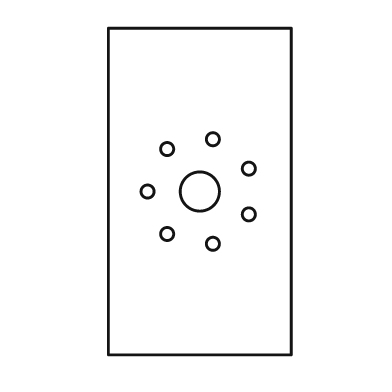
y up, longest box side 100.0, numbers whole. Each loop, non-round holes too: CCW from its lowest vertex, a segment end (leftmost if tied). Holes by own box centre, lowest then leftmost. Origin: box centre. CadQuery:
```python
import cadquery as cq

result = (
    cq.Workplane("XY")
    .moveTo(-28.0, -50.0)
    .lineTo(28.0, -50.0)
    .lineTo(28.0, 50.0)
    .lineTo(-28.0, 50.0)
    .close()
    .moveTo(4.0, -16.0)
    .circle(2.0)
    .moveTo(-10.0, -13.0)
    .circle(2.0)
    .moveTo(15.0, -7.0)
    .circle(2.0)
    .moveTo(-16.0, 0.0)
    .circle(2.0)
    .moveTo(0.0, 0.0)
    .circle(6.0)
    .moveTo(15.0, 7.0)
    .circle(2.0)
    .moveTo(-10.0, 13.0)
    .circle(2.0)
    .moveTo(4.0, 16.0)
    .circle(2.0)
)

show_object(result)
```